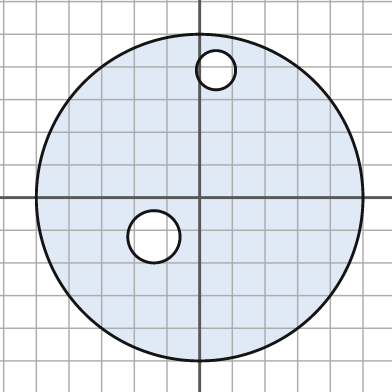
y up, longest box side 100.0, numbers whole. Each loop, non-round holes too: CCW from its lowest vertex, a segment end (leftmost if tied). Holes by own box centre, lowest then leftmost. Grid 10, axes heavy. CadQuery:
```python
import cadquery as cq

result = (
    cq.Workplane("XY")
    .moveTo(0.0, 0.0)
    .circle(50.0)
    .moveTo(-14.0, -12.0)
    .circle(8.0)
    .moveTo(5.0, 39.0)
    .circle(6.0)
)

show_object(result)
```